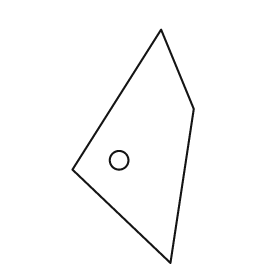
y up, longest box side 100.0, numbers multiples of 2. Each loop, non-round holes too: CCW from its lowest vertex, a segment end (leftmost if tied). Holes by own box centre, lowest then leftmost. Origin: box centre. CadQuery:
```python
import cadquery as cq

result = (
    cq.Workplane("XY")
    .moveTo(16.0, -50.0)
    .lineTo(26.0, 16.0)
    .lineTo(12.0, 50.0)
    .lineTo(-26.0, -10.0)
    .close()
    .moveTo(-6.0, -6.0)
    .circle(4.0)
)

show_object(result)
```